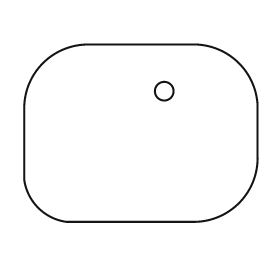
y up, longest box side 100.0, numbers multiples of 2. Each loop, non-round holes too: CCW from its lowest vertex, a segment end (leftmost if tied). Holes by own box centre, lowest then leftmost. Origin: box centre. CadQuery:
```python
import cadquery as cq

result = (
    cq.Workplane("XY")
    .moveTo(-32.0, -38.0)
    .lineTo(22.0, -38.0)
    .threePointArc((42.0, -30.0), (50.0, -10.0))
    .lineTo(50.0, 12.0)
    .threePointArc((42.0, 30.0), (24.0, 38.0))
    .lineTo(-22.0, 38.0)
    .threePointArc((-42.0, 30.0), (-50.0, 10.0))
    .lineTo(-50.0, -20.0)
    .threePointArc((-44.0, -32.0), (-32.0, -38.0))
    .close()
    .moveTo(10.0, 18.0)
    .circle(4.0)
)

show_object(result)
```